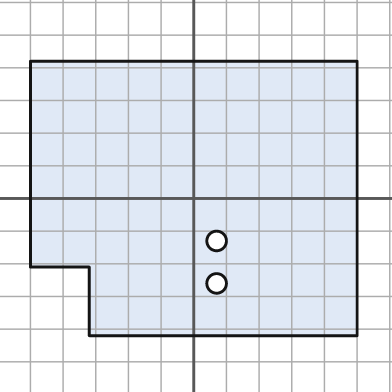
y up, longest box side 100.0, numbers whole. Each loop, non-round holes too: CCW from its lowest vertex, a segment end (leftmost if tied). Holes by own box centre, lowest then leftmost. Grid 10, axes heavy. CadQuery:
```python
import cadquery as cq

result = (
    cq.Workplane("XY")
    .moveTo(-32.0, -42.0)
    .lineTo(50.0, -42.0)
    .lineTo(50.0, 42.0)
    .lineTo(-50.0, 42.0)
    .lineTo(-50.0, -21.0)
    .lineTo(-32.0, -21.0)
    .close()
    .moveTo(7.0, -26.0)
    .circle(3.0)
    .moveTo(7.0, -13.0)
    .circle(3.0)
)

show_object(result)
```